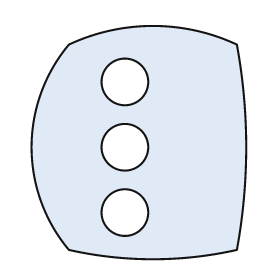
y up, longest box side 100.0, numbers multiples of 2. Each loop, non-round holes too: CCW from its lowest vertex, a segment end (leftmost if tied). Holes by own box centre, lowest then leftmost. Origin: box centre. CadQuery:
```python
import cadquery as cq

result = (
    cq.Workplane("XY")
    .moveTo(-30.0, -46.0)
    .threePointArc((6.0, -50.0), (42.0, -46.0))
    .threePointArc((46.0, -2.0), (42.0, 42.0))
    .threePointArc((6.0, 50.0), (-30.0, 42.0))
    .threePointArc((-46.0, -2.0), (-30.0, -46.0))
    .close()
    .moveTo(-6.0, -30.0)
    .circle(10.0)
    .moveTo(-6.0, -2.0)
    .circle(10.0)
    .moveTo(-6.0, 26.0)
    .circle(10.0)
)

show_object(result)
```